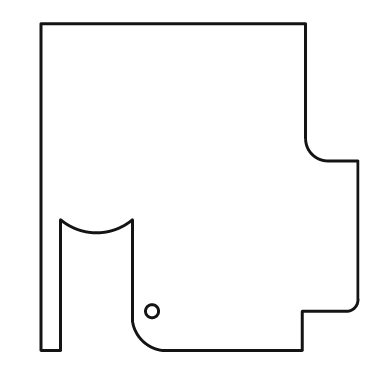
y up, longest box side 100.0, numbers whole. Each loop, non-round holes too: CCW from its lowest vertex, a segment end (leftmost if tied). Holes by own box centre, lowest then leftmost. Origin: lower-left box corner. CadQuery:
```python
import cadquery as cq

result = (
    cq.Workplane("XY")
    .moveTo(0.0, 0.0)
    .lineTo(6.0, 0.0)
    .lineTo(6.0, 40.0)
    .threePointArc((17.0, 36.0), (28.0, 40.0))
    .lineTo(28.0, 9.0)
    .threePointArc((31.0, 3.0), (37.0, 0.0))
    .lineTo(80.0, 0.0)
    .lineTo(80.0, 12.0)
    .lineTo(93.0, 12.0)
    .threePointArc((96.0, 13.0), (97.0, 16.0))
    .lineTo(97.0, 58.0)
    .lineTo(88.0, 58.0)
    .threePointArc((83.0, 60.0), (81.0, 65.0))
    .lineTo(81.0, 100.0)
    .lineTo(0.0, 100.0)
    .close()
    .moveTo(34.0, 12.0)
    .circle(2.0)
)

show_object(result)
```